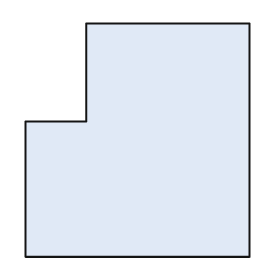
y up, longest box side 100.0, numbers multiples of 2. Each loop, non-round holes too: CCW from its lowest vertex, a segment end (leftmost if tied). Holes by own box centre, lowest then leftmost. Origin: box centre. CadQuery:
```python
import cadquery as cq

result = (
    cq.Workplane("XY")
    .moveTo(-48.0, -50.0)
    .lineTo(48.0, -50.0)
    .lineTo(48.0, 50.0)
    .lineTo(-22.0, 50.0)
    .lineTo(-22.0, 8.0)
    .lineTo(-48.0, 8.0)
    .close()
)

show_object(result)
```